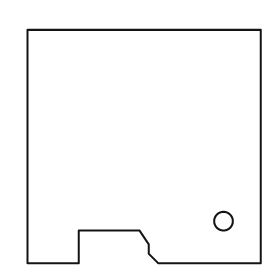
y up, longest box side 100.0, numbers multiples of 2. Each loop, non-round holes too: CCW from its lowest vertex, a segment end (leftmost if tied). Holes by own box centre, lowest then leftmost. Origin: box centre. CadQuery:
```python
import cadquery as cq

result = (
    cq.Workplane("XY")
    .moveTo(-50.0, -50.0)
    .lineTo(-28.0, -50.0)
    .lineTo(-28.0, -36.0)
    .lineTo(-2.0, -36.0)
    .lineTo(2.0, -42.0)
    .lineTo(2.0, -46.0)
    .lineTo(6.0, -50.0)
    .lineTo(50.0, -50.0)
    .lineTo(50.0, 50.0)
    .lineTo(-50.0, 50.0)
    .close()
    .moveTo(34.0, -32.0)
    .circle(4.0)
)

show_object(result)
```